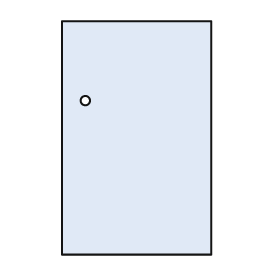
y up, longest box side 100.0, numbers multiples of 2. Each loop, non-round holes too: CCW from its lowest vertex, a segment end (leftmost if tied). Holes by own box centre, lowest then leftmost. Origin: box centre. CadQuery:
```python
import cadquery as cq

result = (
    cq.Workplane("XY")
    .moveTo(-32.0, -50.0)
    .lineTo(32.0, -50.0)
    .lineTo(32.0, 50.0)
    .lineTo(-32.0, 50.0)
    .close()
    .moveTo(-22.0, 16.0)
    .circle(2.0)
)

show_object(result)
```